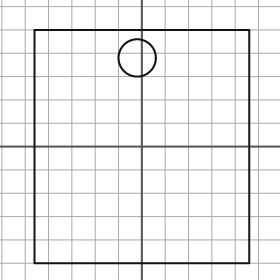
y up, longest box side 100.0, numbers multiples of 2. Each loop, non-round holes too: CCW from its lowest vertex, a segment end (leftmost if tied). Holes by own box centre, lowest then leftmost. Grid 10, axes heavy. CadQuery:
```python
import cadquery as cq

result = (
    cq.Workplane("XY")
    .moveTo(-46.0, -50.0)
    .lineTo(46.0, -50.0)
    .lineTo(46.0, 50.0)
    .lineTo(-46.0, 50.0)
    .close()
    .moveTo(-2.0, 38.0)
    .circle(8.0)
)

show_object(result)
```